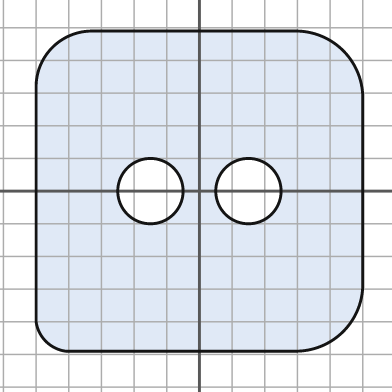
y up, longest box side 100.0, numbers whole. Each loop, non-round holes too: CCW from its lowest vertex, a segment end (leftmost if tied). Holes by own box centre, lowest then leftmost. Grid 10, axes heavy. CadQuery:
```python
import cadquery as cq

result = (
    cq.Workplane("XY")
    .moveTo(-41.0, -49.0)
    .lineTo(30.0, -49.0)
    .threePointArc((44.0, -43.0), (50.0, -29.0))
    .lineTo(50.0, 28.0)
    .threePointArc((44.0, 43.0), (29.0, 49.0))
    .lineTo(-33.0, 49.0)
    .threePointArc((-45.0, 44.0), (-50.0, 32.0))
    .lineTo(-50.0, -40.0)
    .threePointArc((-47.0, -46.0), (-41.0, -49.0))
    .close()
    .moveTo(-15.0, 0.0)
    .circle(10.0)
    .moveTo(15.0, 0.0)
    .circle(10.0)
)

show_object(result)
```